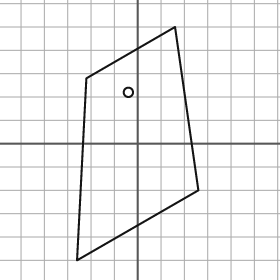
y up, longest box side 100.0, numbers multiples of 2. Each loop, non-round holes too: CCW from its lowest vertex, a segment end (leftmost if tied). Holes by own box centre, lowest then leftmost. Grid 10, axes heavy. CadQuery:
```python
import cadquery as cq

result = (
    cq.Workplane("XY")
    .moveTo(-26.0, -50.0)
    .lineTo(26.0, -20.0)
    .lineTo(16.0, 50.0)
    .lineTo(-22.0, 28.0)
    .close()
    .moveTo(-4.0, 22.0)
    .circle(2.0)
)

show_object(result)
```